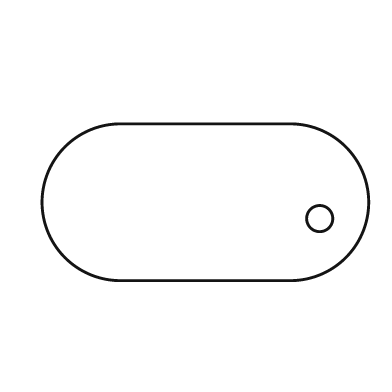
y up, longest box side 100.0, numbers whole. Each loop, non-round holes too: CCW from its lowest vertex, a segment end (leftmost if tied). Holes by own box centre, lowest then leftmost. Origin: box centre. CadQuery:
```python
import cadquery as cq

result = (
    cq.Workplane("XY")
    .moveTo(-26.0, -24.0)
    .lineTo(26.0, -24.0)
    .threePointArc((50.0, 0.0), (26.0, 24.0))
    .lineTo(-26.0, 24.0)
    .threePointArc((-50.0, 0.0), (-26.0, -24.0))
    .close()
    .moveTo(35.0, -5.0)
    .circle(4.0)
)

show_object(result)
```